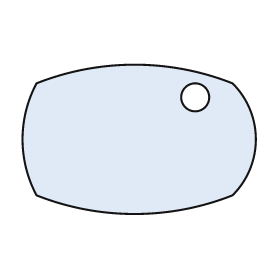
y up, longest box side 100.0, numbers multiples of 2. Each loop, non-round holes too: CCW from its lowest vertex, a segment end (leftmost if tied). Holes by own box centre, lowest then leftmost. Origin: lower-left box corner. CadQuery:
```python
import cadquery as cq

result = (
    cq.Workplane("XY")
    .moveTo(6.0, 8.0)
    .threePointArc((48.0, 0.0), (90.0, 8.0))
    .threePointArc((100.0, 32.0), (90.0, 56.0))
    .threePointArc((48.0, 64.0), (6.0, 56.0))
    .threePointArc((0.0, 32.0), (6.0, 8.0))
    .close()
    .moveTo(74.0, 50.0)
    .circle(6.0)
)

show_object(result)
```